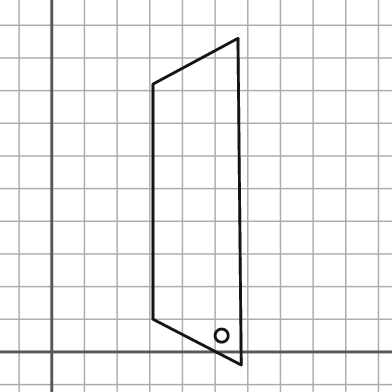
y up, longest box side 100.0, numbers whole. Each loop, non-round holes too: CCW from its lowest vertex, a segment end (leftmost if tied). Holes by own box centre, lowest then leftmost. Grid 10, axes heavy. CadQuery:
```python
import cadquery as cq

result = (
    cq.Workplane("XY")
    .moveTo(58.0, -4.0)
    .lineTo(57.0, 96.0)
    .lineTo(31.0, 82.0)
    .lineTo(31.0, 10.0)
    .close()
    .moveTo(52.0, 5.0)
    .circle(2.0)
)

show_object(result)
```